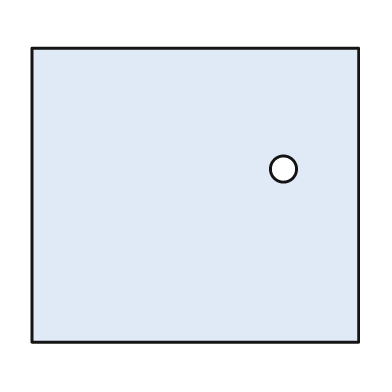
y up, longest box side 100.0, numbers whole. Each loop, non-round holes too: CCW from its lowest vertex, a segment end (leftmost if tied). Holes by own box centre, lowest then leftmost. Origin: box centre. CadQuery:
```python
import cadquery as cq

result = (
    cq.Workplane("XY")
    .moveTo(-50.0, -45.0)
    .lineTo(50.0, -45.0)
    .lineTo(50.0, 45.0)
    .lineTo(-50.0, 45.0)
    .close()
    .moveTo(27.0, 8.0)
    .circle(4.0)
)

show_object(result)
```